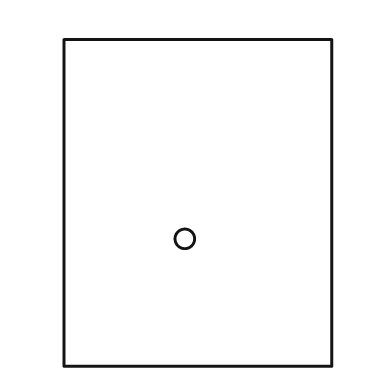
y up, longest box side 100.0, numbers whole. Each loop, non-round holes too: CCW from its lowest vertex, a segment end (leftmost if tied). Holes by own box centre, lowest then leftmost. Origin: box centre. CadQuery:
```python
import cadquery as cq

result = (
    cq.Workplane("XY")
    .moveTo(-41.0, -50.0)
    .lineTo(41.0, -50.0)
    .lineTo(41.0, 50.0)
    .lineTo(-41.0, 50.0)
    .close()
    .moveTo(-4.0, -11.0)
    .circle(3.0)
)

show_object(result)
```